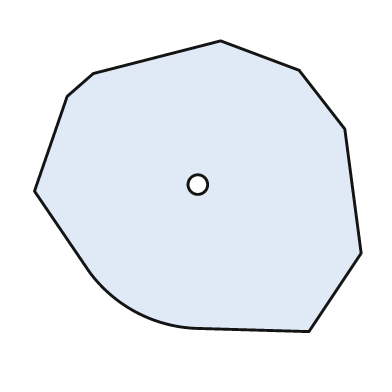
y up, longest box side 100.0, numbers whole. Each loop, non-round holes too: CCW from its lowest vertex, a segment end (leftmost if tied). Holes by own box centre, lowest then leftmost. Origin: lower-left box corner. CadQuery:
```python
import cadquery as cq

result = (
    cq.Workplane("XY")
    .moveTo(84.0, 0.0)
    .lineTo(100.0, 24.0)
    .lineTo(95.0, 62.0)
    .lineTo(81.0, 80.0)
    .lineTo(57.0, 89.0)
    .lineTo(18.0, 79.0)
    .lineTo(10.0, 72.0)
    .lineTo(0.0, 43.0)
    .lineTo(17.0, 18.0)
    .threePointArc((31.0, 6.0), (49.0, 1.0))
    .close()
    .moveTo(50.0, 45.0)
    .circle(3.0)
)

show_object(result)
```